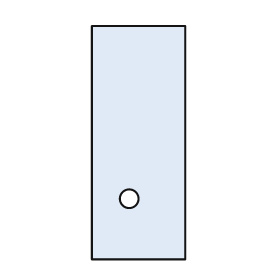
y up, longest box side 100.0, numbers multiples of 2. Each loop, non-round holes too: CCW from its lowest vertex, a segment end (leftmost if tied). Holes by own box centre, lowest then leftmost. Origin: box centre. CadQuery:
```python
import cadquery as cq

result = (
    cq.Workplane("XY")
    .moveTo(-20.0, -50.0)
    .lineTo(20.0, -50.0)
    .lineTo(20.0, 50.0)
    .lineTo(-20.0, 50.0)
    .close()
    .moveTo(-4.0, -24.0)
    .circle(4.0)
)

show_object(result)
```